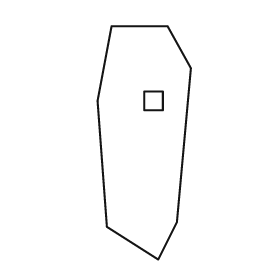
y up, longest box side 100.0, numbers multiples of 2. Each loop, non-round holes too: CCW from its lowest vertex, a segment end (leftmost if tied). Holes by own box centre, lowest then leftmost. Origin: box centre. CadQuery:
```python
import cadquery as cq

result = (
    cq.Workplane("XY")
    .moveTo(6.0, -50.0)
    .lineTo(14.0, -34.0)
    .lineTo(20.0, 32.0)
    .lineTo(10.0, 50.0)
    .lineTo(-14.0, 50.0)
    .lineTo(-20.0, 18.0)
    .lineTo(-16.0, -36.0)
    .close()
    .moveTo(0.0, 14.0)
    .lineTo(8.0, 14.0)
    .lineTo(8.0, 22.0)
    .lineTo(0.0, 22.0)
    .close()
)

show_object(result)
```